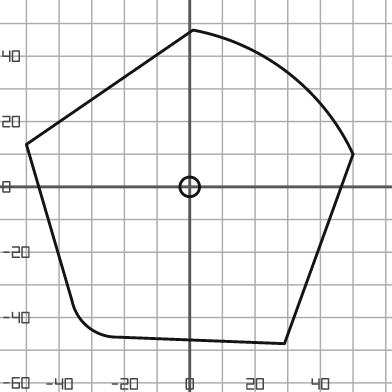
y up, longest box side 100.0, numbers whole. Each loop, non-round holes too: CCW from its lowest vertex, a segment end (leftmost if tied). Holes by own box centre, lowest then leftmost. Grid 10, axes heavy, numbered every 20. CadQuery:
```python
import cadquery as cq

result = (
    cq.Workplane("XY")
    .moveTo(29.0, -48.0)
    .lineTo(50.0, 10.0)
    .threePointArc((30.0, 35.0), (1.0, 48.0))
    .lineTo(-50.0, 13.0)
    .lineTo(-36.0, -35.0)
    .threePointArc((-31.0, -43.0), (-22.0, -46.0))
    .close()
    .moveTo(0.0, 0.0)
    .circle(3.0)
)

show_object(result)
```